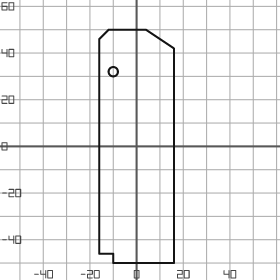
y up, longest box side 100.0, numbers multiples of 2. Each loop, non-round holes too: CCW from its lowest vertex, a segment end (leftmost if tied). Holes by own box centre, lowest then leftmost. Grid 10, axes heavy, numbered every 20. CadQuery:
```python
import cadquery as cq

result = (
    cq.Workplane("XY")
    .moveTo(-10.0, -50.0)
    .lineTo(16.0, -50.0)
    .lineTo(16.0, 42.0)
    .lineTo(4.0, 50.0)
    .lineTo(-12.0, 50.0)
    .lineTo(-16.0, 46.0)
    .lineTo(-16.0, -46.0)
    .lineTo(-10.0, -46.0)
    .close()
    .moveTo(-10.0, 32.0)
    .circle(2.0)
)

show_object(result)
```